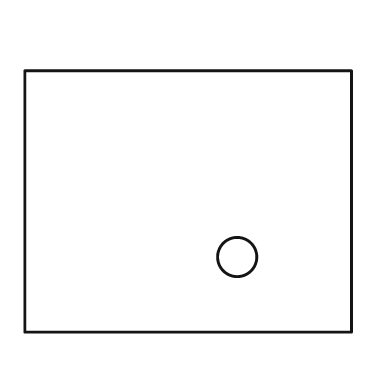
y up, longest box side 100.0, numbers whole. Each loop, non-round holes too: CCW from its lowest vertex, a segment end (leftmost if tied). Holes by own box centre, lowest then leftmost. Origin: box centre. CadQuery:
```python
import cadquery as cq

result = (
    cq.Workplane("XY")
    .moveTo(-50.0, -40.0)
    .lineTo(50.0, -40.0)
    .lineTo(50.0, 40.0)
    .lineTo(-50.0, 40.0)
    .close()
    .moveTo(15.0, -17.0)
    .circle(6.0)
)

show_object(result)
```